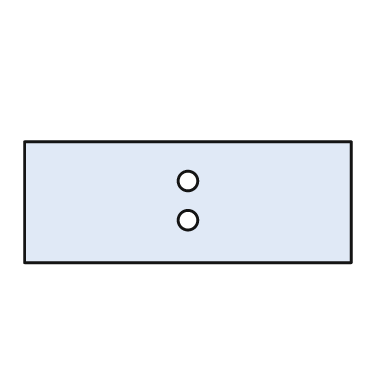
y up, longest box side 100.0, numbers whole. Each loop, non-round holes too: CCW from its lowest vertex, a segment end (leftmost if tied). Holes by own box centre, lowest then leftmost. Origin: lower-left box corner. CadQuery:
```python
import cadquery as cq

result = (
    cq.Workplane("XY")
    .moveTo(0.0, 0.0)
    .lineTo(100.0, 0.0)
    .lineTo(100.0, 37.0)
    .lineTo(0.0, 37.0)
    .close()
    .moveTo(50.0, 13.0)
    .circle(3.0)
    .moveTo(50.0, 25.0)
    .circle(3.0)
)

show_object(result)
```